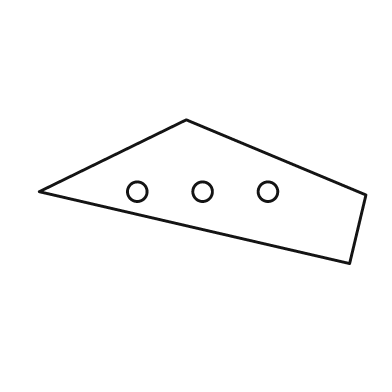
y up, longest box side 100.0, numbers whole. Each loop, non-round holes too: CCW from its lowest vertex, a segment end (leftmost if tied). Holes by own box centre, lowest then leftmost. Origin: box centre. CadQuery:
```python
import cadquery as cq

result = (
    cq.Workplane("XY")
    .moveTo(45.0, -22.0)
    .lineTo(50.0, -1.0)
    .lineTo(-5.0, 22.0)
    .lineTo(-50.0, 0.0)
    .close()
    .moveTo(-20.0, 0.0)
    .circle(3.0)
    .moveTo(0.0, 0.0)
    .circle(3.0)
    .moveTo(20.0, 0.0)
    .circle(3.0)
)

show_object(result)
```